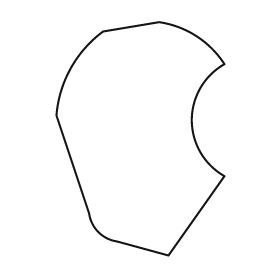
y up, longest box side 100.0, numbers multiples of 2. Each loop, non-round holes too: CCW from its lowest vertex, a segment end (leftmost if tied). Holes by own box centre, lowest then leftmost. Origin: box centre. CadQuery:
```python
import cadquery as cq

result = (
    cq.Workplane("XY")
    .moveTo(12.0, -50.0)
    .lineTo(36.0, -16.0)
    .threePointArc((22.0, 8.0), (36.0, 32.0))
    .threePointArc((24.0, 44.0), (8.0, 50.0))
    .lineTo(-16.0, 46.0)
    .threePointArc((-30.0, 30.0), (-36.0, 10.0))
    .lineTo(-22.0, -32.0)
    .threePointArc((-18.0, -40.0), (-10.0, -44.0))
    .close()
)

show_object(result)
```